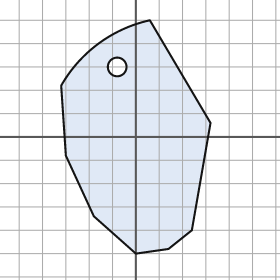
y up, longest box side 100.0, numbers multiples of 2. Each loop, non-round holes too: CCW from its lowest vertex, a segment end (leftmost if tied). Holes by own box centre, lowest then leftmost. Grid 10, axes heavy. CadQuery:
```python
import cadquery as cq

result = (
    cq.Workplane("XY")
    .moveTo(0.0, -50.0)
    .lineTo(14.0, -48.0)
    .lineTo(24.0, -40.0)
    .lineTo(32.0, 6.0)
    .lineTo(6.0, 50.0)
    .threePointArc((-16.0, 40.0), (-32.0, 22.0))
    .lineTo(-30.0, -8.0)
    .lineTo(-18.0, -34.0)
    .close()
    .moveTo(-8.0, 30.0)
    .circle(4.0)
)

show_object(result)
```